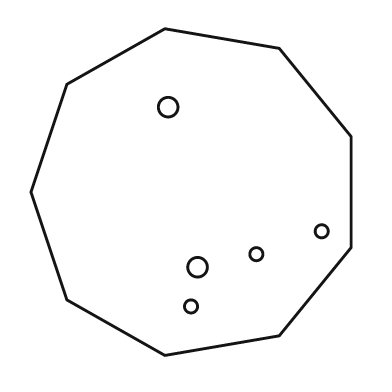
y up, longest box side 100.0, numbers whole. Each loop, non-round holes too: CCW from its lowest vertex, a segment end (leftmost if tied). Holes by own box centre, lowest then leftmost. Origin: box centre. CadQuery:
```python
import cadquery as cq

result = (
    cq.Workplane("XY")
    .moveTo(-8.0, -50.0)
    .lineTo(27.0, -44.0)
    .lineTo(49.0, -17.0)
    .lineTo(49.0, 17.0)
    .lineTo(27.0, 44.0)
    .lineTo(-8.0, 50.0)
    .lineTo(-38.0, 33.0)
    .lineTo(-49.0, 0.0)
    .lineTo(-38.0, -33.0)
    .close()
    .moveTo(0.0, -35.0)
    .circle(2.0)
    .moveTo(2.0, -23.0)
    .circle(3.0)
    .moveTo(20.0, -19.0)
    .circle(2.0)
    .moveTo(40.0, -12.0)
    .circle(2.0)
    .moveTo(-7.0, 26.0)
    .circle(3.0)
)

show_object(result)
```